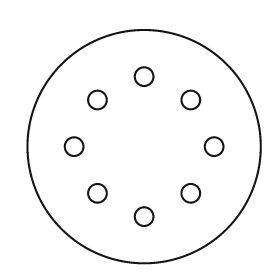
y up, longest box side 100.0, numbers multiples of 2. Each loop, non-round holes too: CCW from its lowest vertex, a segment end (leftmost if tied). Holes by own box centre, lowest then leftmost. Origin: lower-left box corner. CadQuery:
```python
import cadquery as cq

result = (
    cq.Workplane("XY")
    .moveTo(50.0, 50.0)
    .circle(50.0)
    .moveTo(50.0, 20.0)
    .circle(4.0)
    .moveTo(30.0, 30.0)
    .circle(4.0)
    .moveTo(70.0, 30.0)
    .circle(4.0)
    .moveTo(20.0, 50.0)
    .circle(4.0)
    .moveTo(80.0, 50.0)
    .circle(4.0)
    .moveTo(30.0, 70.0)
    .circle(4.0)
    .moveTo(70.0, 70.0)
    .circle(4.0)
    .moveTo(50.0, 80.0)
    .circle(4.0)
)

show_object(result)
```